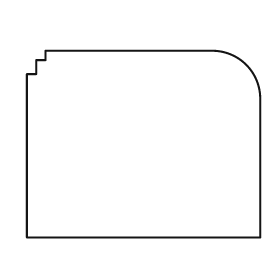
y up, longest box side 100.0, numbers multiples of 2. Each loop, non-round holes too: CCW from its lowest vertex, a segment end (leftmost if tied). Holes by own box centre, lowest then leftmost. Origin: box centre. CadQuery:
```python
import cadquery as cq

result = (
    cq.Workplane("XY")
    .moveTo(-50.0, -40.0)
    .lineTo(50.0, -40.0)
    .lineTo(50.0, 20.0)
    .threePointArc((44.0, 34.0), (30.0, 40.0))
    .lineTo(-42.0, 40.0)
    .lineTo(-42.0, 36.0)
    .lineTo(-46.0, 36.0)
    .lineTo(-46.0, 30.0)
    .lineTo(-50.0, 30.0)
    .close()
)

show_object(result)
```